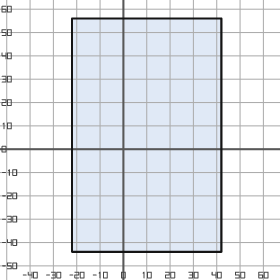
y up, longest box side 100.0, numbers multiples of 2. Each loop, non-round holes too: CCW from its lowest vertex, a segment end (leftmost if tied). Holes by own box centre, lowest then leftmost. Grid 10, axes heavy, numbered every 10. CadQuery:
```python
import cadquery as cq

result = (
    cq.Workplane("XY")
    .moveTo(-22.0, -44.0)
    .lineTo(42.0, -44.0)
    .lineTo(42.0, 56.0)
    .lineTo(-22.0, 56.0)
    .close()
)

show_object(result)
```